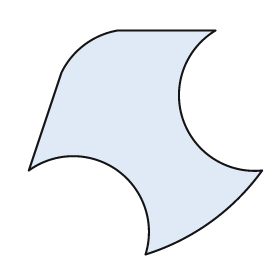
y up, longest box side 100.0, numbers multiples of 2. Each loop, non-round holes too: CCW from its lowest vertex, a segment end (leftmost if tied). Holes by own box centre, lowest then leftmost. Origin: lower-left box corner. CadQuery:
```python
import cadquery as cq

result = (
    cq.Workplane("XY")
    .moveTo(50.0, 0.0)
    .threePointArc((78.0, 14.0), (100.0, 36.0))
    .threePointArc((66.0, 58.0), (80.0, 96.0))
    .lineTo(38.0, 96.0)
    .threePointArc((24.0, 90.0), (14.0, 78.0))
    .lineTo(0.0, 36.0)
    .threePointArc((38.0, 36.0), (50.0, 0.0))
    .close()
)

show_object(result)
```